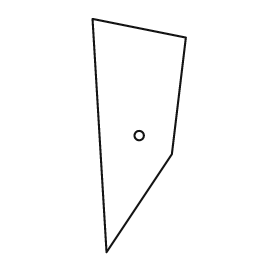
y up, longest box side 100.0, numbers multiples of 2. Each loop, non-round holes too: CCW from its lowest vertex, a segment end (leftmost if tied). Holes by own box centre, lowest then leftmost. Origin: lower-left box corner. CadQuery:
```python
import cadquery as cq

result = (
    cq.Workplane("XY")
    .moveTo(6.0, 0.0)
    .lineTo(34.0, 42.0)
    .lineTo(40.0, 92.0)
    .lineTo(0.0, 100.0)
    .close()
    .moveTo(20.0, 50.0)
    .circle(2.0)
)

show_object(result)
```